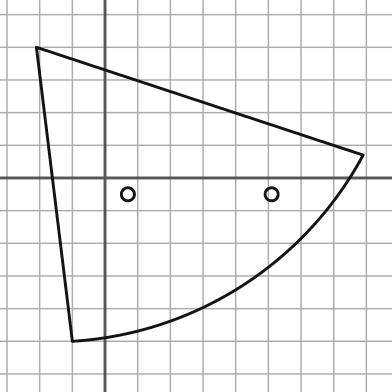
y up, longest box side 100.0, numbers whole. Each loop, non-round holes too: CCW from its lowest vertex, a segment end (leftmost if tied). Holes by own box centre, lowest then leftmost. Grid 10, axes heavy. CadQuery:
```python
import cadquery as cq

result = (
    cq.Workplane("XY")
    .moveTo(-10.0, -50.0)
    .threePointArc((42.0, -33.0), (79.0, 7.0))
    .lineTo(-21.0, 40.0)
    .close()
    .moveTo(7.0, -5.0)
    .circle(2.0)
    .moveTo(51.0, -5.0)
    .circle(2.0)
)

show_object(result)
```